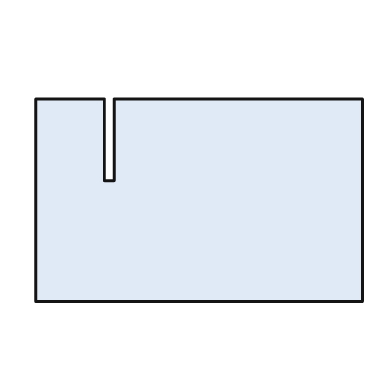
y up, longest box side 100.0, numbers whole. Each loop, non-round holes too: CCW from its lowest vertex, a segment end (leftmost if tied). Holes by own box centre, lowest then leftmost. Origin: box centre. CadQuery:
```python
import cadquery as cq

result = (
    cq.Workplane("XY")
    .moveTo(-50.0, -31.0)
    .lineTo(50.0, -31.0)
    .lineTo(50.0, 31.0)
    .lineTo(-26.0, 31.0)
    .lineTo(-26.0, 6.0)
    .lineTo(-29.0, 6.0)
    .lineTo(-29.0, 31.0)
    .lineTo(-50.0, 31.0)
    .close()
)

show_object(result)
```